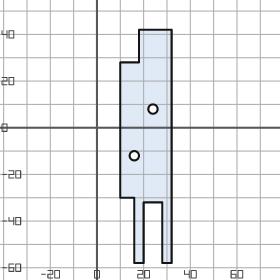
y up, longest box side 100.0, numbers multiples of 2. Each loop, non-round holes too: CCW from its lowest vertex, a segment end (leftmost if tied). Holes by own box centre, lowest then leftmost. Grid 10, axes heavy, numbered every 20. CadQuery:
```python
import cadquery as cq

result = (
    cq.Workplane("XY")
    .moveTo(16.0, -58.0)
    .lineTo(20.0, -58.0)
    .lineTo(20.0, -32.0)
    .lineTo(28.0, -32.0)
    .lineTo(28.0, -58.0)
    .lineTo(32.0, -58.0)
    .lineTo(32.0, 42.0)
    .lineTo(18.0, 42.0)
    .lineTo(18.0, 28.0)
    .lineTo(10.0, 28.0)
    .lineTo(10.0, -30.0)
    .lineTo(16.0, -30.0)
    .close()
    .moveTo(16.0, -12.0)
    .circle(2.0)
    .moveTo(24.0, 8.0)
    .circle(2.0)
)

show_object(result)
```